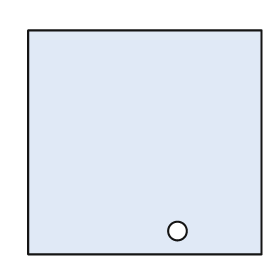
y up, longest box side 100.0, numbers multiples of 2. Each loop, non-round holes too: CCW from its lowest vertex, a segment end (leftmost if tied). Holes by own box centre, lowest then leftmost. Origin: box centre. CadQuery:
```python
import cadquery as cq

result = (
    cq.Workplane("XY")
    .moveTo(-50.0, -48.0)
    .lineTo(50.0, -48.0)
    .lineTo(50.0, 48.0)
    .lineTo(-50.0, 48.0)
    .close()
    .moveTo(14.0, -38.0)
    .circle(4.0)
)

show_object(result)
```